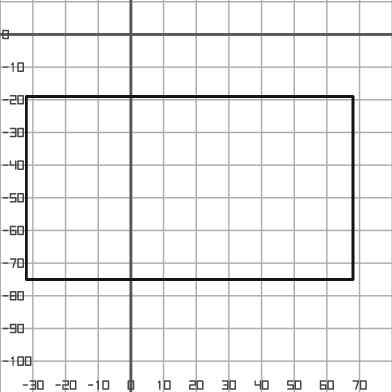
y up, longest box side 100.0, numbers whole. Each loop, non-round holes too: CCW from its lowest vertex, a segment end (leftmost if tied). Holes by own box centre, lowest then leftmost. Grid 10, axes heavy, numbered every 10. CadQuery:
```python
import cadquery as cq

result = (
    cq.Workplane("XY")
    .moveTo(-32.0, -75.0)
    .lineTo(68.0, -75.0)
    .lineTo(68.0, -19.0)
    .lineTo(-32.0, -19.0)
    .close()
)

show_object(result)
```